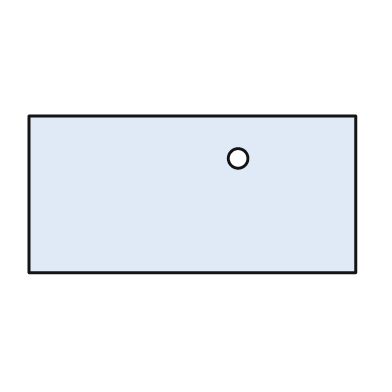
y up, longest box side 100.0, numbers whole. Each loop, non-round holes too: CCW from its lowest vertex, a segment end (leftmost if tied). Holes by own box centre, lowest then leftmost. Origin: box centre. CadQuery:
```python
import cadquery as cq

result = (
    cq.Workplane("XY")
    .moveTo(-50.0, -24.0)
    .lineTo(50.0, -24.0)
    .lineTo(50.0, 24.0)
    .lineTo(-50.0, 24.0)
    .close()
    .moveTo(14.0, 11.0)
    .circle(3.0)
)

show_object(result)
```